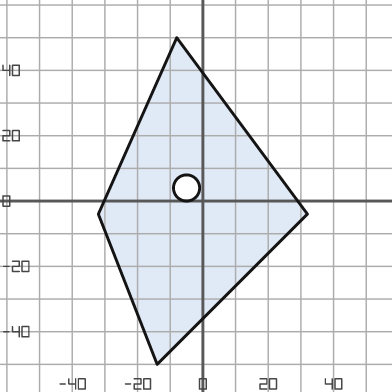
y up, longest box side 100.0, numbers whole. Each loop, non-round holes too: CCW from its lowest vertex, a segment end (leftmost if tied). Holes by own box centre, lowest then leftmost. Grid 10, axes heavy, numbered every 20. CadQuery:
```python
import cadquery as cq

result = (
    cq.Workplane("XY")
    .moveTo(-14.0, -50.0)
    .lineTo(32.0, -4.0)
    .lineTo(-8.0, 50.0)
    .lineTo(-32.0, -4.0)
    .close()
    .moveTo(-5.0, 4.0)
    .circle(4.0)
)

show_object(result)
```